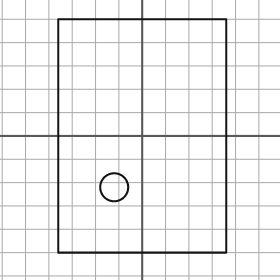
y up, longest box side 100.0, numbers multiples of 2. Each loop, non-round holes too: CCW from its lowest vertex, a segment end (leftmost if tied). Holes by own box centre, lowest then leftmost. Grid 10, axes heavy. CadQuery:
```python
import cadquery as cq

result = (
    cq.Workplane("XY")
    .moveTo(-36.0, -50.0)
    .lineTo(36.0, -50.0)
    .lineTo(36.0, 50.0)
    .lineTo(-36.0, 50.0)
    .close()
    .moveTo(-12.0, -22.0)
    .circle(6.0)
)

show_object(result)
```